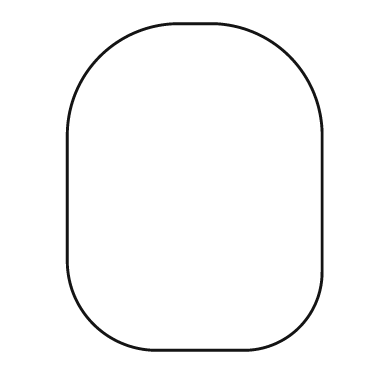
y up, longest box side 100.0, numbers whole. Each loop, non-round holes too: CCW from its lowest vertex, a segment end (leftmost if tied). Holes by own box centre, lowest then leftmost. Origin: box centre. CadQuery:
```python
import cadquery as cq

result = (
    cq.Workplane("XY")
    .moveTo(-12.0, -50.0)
    .lineTo(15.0, -50.0)
    .threePointArc((32.0, -43.0), (39.0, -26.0))
    .lineTo(39.0, 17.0)
    .threePointArc((29.0, 40.0), (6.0, 50.0))
    .lineTo(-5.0, 50.0)
    .threePointArc((-29.0, 40.0), (-39.0, 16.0))
    .lineTo(-39.0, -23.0)
    .threePointArc((-31.0, -42.0), (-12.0, -50.0))
    .close()
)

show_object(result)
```